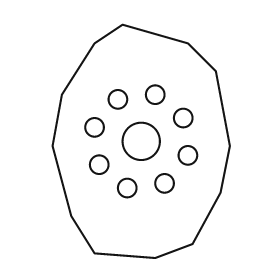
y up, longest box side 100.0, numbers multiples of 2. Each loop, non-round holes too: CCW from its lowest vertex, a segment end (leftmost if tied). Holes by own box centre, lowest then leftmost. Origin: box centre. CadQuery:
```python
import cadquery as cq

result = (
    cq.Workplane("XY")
    .moveTo(6.0, -50.0)
    .lineTo(22.0, -44.0)
    .lineTo(34.0, -22.0)
    .lineTo(38.0, -2.0)
    .lineTo(32.0, 30.0)
    .lineTo(20.0, 42.0)
    .lineTo(-8.0, 50.0)
    .lineTo(-20.0, 42.0)
    .lineTo(-34.0, 20.0)
    .lineTo(-38.0, -2.0)
    .lineTo(-30.0, -32.0)
    .lineTo(-20.0, -48.0)
    .close()
    .moveTo(-6.0, -20.0)
    .circle(4.0)
    .moveTo(10.0, -18.0)
    .circle(4.0)
    .moveTo(-18.0, -10.0)
    .circle(4.0)
    .moveTo(20.0, -6.0)
    .circle(4.0)
    .moveTo(0.0, 0.0)
    .circle(8.0)
    .moveTo(-20.0, 6.0)
    .circle(4.0)
    .moveTo(18.0, 10.0)
    .circle(4.0)
    .moveTo(-10.0, 18.0)
    .circle(4.0)
    .moveTo(6.0, 20.0)
    .circle(4.0)
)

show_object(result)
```